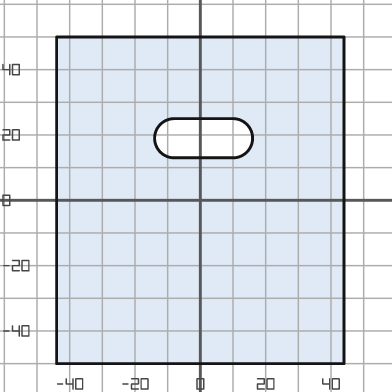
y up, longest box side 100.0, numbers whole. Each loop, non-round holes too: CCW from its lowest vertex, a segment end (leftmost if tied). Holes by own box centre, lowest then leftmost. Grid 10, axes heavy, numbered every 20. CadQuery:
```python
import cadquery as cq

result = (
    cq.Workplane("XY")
    .moveTo(-44.0, -50.0)
    .lineTo(44.0, -50.0)
    .lineTo(44.0, 50.0)
    .lineTo(-44.0, 50.0)
    .close()
    .moveTo(-8.0, 13.0)
    .lineTo(10.0, 13.0)
    .threePointArc((16.0, 19.0), (10.0, 25.0))
    .lineTo(-8.0, 25.0)
    .threePointArc((-14.0, 19.0), (-8.0, 13.0))
    .close()
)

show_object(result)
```